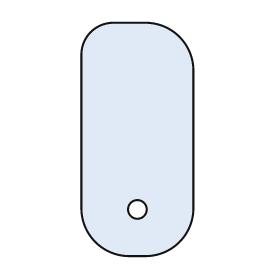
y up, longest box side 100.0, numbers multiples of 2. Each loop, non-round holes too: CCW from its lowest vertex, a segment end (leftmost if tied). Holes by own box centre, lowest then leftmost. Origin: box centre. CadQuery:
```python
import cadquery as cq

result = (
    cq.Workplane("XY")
    .moveTo(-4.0, -50.0)
    .lineTo(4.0, -50.0)
    .threePointArc((18.0, -44.0), (24.0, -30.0))
    .lineTo(24.0, 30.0)
    .threePointArc((18.0, 44.0), (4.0, 50.0))
    .lineTo(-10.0, 50.0)
    .threePointArc((-20.0, 46.0), (-24.0, 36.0))
    .lineTo(-24.0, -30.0)
    .threePointArc((-18.0, -44.0), (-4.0, -50.0))
    .close()
    .moveTo(0.0, -30.0)
    .circle(4.0)
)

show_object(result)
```